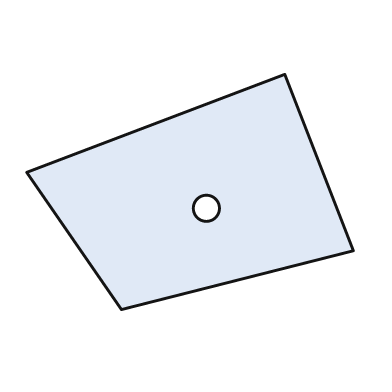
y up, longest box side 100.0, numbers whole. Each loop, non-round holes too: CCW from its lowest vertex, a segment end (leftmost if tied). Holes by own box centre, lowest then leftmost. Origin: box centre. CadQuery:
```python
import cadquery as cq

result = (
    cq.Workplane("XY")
    .moveTo(-21.0, -36.0)
    .lineTo(50.0, -18.0)
    .lineTo(29.0, 36.0)
    .lineTo(-50.0, 6.0)
    .close()
    .moveTo(5.0, -5.0)
    .circle(4.0)
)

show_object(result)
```